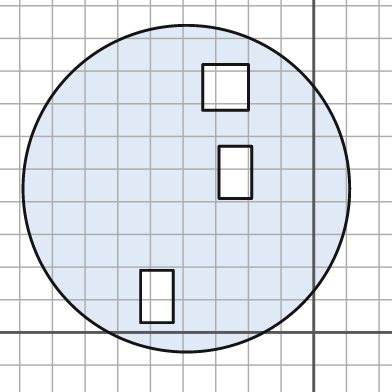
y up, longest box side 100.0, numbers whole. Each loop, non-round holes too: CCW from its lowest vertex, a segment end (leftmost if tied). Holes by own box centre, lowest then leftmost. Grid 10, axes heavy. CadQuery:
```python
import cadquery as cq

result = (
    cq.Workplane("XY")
    .moveTo(-39.0, 44.0)
    .circle(50.0)
    .moveTo(-53.0, 3.0)
    .lineTo(-43.0, 3.0)
    .lineTo(-43.0, 19.0)
    .lineTo(-53.0, 19.0)
    .close()
    .moveTo(-29.0, 41.0)
    .lineTo(-19.0, 41.0)
    .lineTo(-19.0, 57.0)
    .lineTo(-29.0, 57.0)
    .close()
    .moveTo(-34.0, 68.0)
    .lineTo(-20.0, 68.0)
    .lineTo(-20.0, 82.0)
    .lineTo(-34.0, 82.0)
    .close()
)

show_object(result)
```